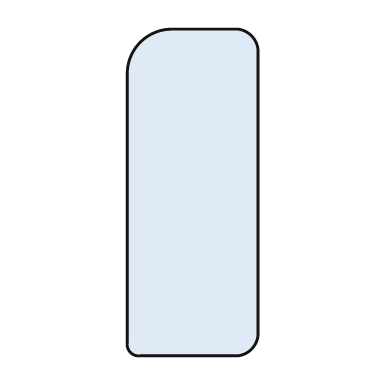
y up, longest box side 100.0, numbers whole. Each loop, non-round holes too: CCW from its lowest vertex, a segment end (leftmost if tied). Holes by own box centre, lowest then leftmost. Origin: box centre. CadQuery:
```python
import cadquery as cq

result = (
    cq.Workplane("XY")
    .moveTo(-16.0, -50.0)
    .lineTo(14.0, -50.0)
    .threePointArc((18.0, -48.0), (20.0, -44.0))
    .lineTo(20.0, 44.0)
    .threePointArc((18.0, 48.0), (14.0, 50.0))
    .lineTo(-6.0, 50.0)
    .threePointArc((-16.0, 46.0), (-20.0, 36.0))
    .lineTo(-20.0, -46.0)
    .threePointArc((-19.0, -49.0), (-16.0, -50.0))
    .close()
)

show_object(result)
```